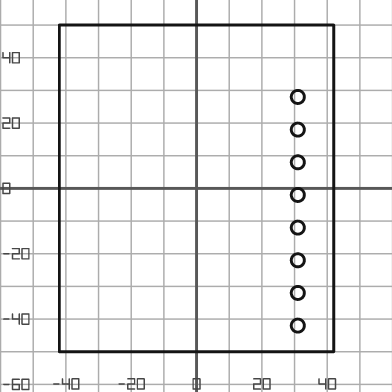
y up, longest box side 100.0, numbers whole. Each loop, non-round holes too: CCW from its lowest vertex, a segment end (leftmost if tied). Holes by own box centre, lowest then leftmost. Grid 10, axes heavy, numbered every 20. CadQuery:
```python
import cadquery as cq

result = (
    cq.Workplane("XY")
    .moveTo(-42.0, -50.0)
    .lineTo(42.0, -50.0)
    .lineTo(42.0, 50.0)
    .lineTo(-42.0, 50.0)
    .close()
    .moveTo(31.0, -42.0)
    .circle(2.0)
    .moveTo(31.0, -32.0)
    .circle(2.0)
    .moveTo(31.0, -22.0)
    .circle(2.0)
    .moveTo(31.0, -12.0)
    .circle(2.0)
    .moveTo(31.0, -2.0)
    .circle(2.0)
    .moveTo(31.0, 8.0)
    .circle(2.0)
    .moveTo(31.0, 18.0)
    .circle(2.0)
    .moveTo(31.0, 28.0)
    .circle(2.0)
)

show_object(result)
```